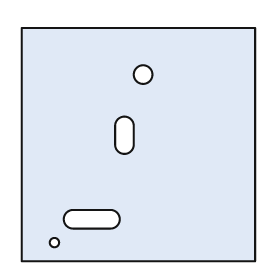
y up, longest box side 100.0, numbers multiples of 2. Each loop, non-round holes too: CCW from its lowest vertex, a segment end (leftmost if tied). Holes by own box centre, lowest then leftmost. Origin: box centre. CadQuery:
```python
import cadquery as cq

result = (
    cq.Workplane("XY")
    .moveTo(-50.0, -50.0)
    .lineTo(50.0, -50.0)
    .lineTo(50.0, 50.0)
    .lineTo(-50.0, 50.0)
    .close()
    .moveTo(-36.0, -42.0)
    .circle(2.0)
    .moveTo(-28.0, -36.0)
    .lineTo(-12.0, -36.0)
    .threePointArc((-8.0, -32.0), (-12.0, -28.0))
    .lineTo(-28.0, -28.0)
    .threePointArc((-32.0, -32.0), (-28.0, -36.0))
    .close()
    .moveTo(-10.0, 0.0)
    .threePointArc((-6.0, -4.0), (-2.0, 0.0))
    .lineTo(-2.0, 8.0)
    .threePointArc((-6.0, 12.0), (-10.0, 8.0))
    .close()
    .moveTo(2.0, 30.0)
    .circle(4.0)
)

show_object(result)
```